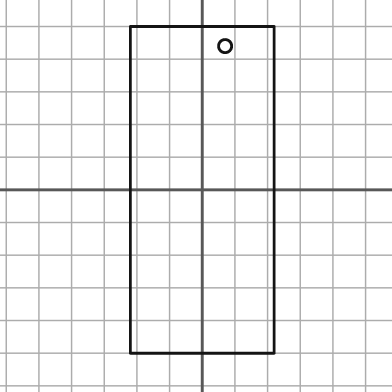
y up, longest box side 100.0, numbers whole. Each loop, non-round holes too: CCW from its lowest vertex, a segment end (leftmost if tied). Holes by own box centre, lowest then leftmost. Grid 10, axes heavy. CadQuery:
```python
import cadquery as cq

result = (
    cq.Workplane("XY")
    .moveTo(-22.0, -50.0)
    .lineTo(22.0, -50.0)
    .lineTo(22.0, 50.0)
    .lineTo(-22.0, 50.0)
    .close()
    .moveTo(7.0, 44.0)
    .circle(2.0)
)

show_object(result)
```